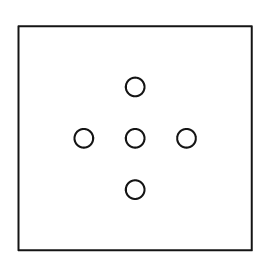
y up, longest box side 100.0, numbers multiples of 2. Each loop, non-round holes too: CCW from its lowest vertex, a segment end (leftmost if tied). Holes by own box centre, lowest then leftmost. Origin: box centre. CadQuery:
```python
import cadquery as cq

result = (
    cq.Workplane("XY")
    .moveTo(-50.0, -48.0)
    .lineTo(50.0, -48.0)
    .lineTo(50.0, 48.0)
    .lineTo(-50.0, 48.0)
    .close()
    .moveTo(0.0, -22.0)
    .circle(4.0)
    .moveTo(-22.0, 0.0)
    .circle(4.0)
    .moveTo(0.0, 0.0)
    .circle(4.0)
    .moveTo(22.0, 0.0)
    .circle(4.0)
    .moveTo(0.0, 22.0)
    .circle(4.0)
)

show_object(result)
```